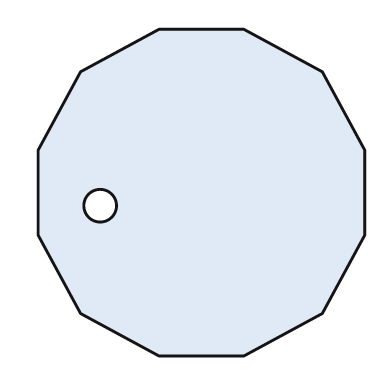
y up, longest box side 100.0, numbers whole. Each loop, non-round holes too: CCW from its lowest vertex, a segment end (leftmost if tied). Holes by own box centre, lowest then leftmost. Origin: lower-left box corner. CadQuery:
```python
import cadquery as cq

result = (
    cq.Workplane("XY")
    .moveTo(37.0, 0.0)
    .lineTo(63.0, 0.0)
    .lineTo(87.0, 13.0)
    .lineTo(100.0, 37.0)
    .lineTo(100.0, 63.0)
    .lineTo(87.0, 87.0)
    .lineTo(63.0, 100.0)
    .lineTo(37.0, 100.0)
    .lineTo(13.0, 87.0)
    .lineTo(0.0, 63.0)
    .lineTo(0.0, 37.0)
    .lineTo(13.0, 13.0)
    .close()
    .moveTo(19.0, 46.0)
    .circle(5.0)
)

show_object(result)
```